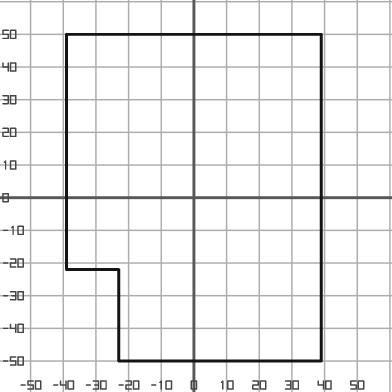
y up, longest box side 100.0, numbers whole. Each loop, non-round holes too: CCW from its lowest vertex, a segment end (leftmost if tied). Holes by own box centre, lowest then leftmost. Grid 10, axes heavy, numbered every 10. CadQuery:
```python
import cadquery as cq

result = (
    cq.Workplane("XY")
    .moveTo(-23.0, -50.0)
    .lineTo(39.0, -50.0)
    .lineTo(39.0, 50.0)
    .lineTo(-39.0, 50.0)
    .lineTo(-39.0, -22.0)
    .lineTo(-23.0, -22.0)
    .close()
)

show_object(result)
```